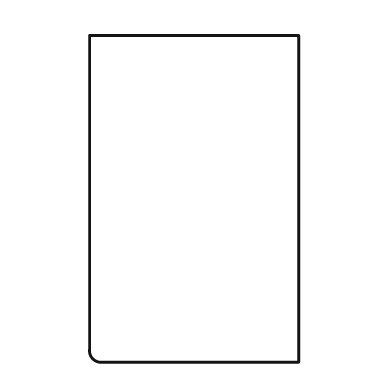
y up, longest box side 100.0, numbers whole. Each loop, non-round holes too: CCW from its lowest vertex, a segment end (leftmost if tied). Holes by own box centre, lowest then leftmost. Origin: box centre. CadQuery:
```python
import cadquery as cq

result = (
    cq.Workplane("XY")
    .moveTo(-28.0, -50.0)
    .lineTo(32.0, -50.0)
    .lineTo(32.0, 50.0)
    .lineTo(-32.0, 50.0)
    .lineTo(-32.0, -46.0)
    .threePointArc((-31.0, -49.0), (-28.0, -50.0))
    .close()
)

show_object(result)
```